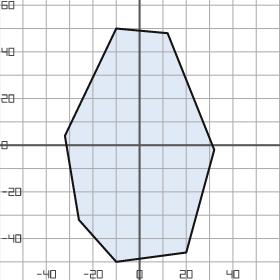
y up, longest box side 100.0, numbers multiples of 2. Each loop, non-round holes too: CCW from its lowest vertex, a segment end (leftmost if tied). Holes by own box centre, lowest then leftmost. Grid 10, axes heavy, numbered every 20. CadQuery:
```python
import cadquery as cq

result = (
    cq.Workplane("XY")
    .moveTo(-10.0, -50.0)
    .lineTo(20.0, -46.0)
    .lineTo(32.0, -2.0)
    .lineTo(12.0, 48.0)
    .lineTo(-10.0, 50.0)
    .lineTo(-32.0, 4.0)
    .lineTo(-26.0, -32.0)
    .close()
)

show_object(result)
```